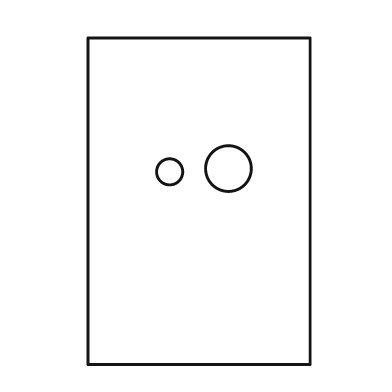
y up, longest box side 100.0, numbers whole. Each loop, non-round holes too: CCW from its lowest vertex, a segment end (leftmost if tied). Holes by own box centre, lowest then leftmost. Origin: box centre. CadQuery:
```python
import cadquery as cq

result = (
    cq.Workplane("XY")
    .moveTo(-34.0, -50.0)
    .lineTo(34.0, -50.0)
    .lineTo(34.0, 50.0)
    .lineTo(-34.0, 50.0)
    .close()
    .moveTo(-9.0, 9.0)
    .circle(4.0)
    .moveTo(9.0, 10.0)
    .circle(7.0)
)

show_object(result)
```